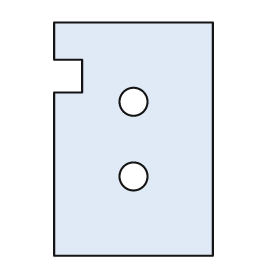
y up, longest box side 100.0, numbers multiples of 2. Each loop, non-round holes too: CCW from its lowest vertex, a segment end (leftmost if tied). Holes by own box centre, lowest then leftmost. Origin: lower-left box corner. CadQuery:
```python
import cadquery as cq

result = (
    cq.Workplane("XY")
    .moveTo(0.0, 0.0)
    .lineTo(68.0, 0.0)
    .lineTo(68.0, 100.0)
    .lineTo(0.0, 100.0)
    .lineTo(0.0, 84.0)
    .lineTo(12.0, 84.0)
    .lineTo(12.0, 70.0)
    .lineTo(0.0, 70.0)
    .close()
    .moveTo(34.0, 34.0)
    .circle(6.0)
    .moveTo(34.0, 66.0)
    .circle(6.0)
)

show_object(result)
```